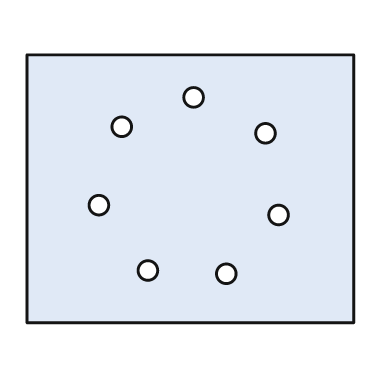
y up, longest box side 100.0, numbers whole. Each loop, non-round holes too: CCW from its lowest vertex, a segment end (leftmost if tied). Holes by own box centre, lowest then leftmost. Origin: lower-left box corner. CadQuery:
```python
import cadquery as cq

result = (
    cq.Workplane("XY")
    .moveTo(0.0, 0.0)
    .lineTo(100.0, 0.0)
    .lineTo(100.0, 82.0)
    .lineTo(0.0, 82.0)
    .close()
    .moveTo(61.0, 15.0)
    .circle(3.0)
    .moveTo(37.0, 16.0)
    .circle(3.0)
    .moveTo(77.0, 33.0)
    .circle(3.0)
    .moveTo(22.0, 36.0)
    .circle(3.0)
    .moveTo(73.0, 58.0)
    .circle(3.0)
    .moveTo(29.0, 60.0)
    .circle(3.0)
    .moveTo(51.0, 69.0)
    .circle(3.0)
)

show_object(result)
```